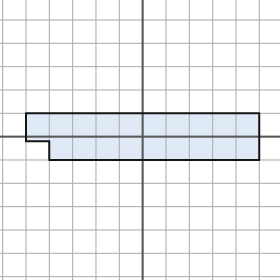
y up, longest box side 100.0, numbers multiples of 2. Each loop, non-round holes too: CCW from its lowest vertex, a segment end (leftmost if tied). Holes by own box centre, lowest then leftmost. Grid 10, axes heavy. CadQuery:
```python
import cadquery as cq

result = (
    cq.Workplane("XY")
    .moveTo(-40.0, -10.0)
    .lineTo(50.0, -10.0)
    .lineTo(50.0, 10.0)
    .lineTo(-50.0, 10.0)
    .lineTo(-50.0, -2.0)
    .lineTo(-40.0, -2.0)
    .close()
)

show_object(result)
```